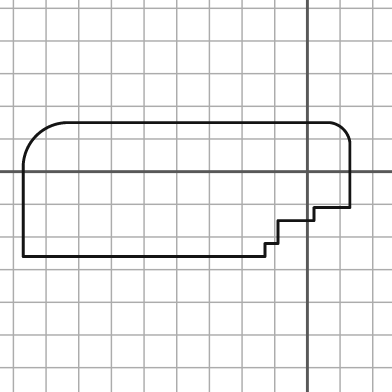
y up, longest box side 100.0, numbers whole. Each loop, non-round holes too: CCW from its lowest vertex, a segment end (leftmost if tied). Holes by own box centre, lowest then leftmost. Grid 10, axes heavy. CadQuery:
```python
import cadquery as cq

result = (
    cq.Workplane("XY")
    .moveTo(-87.0, -26.0)
    .lineTo(-13.0, -26.0)
    .lineTo(-13.0, -22.0)
    .lineTo(-9.0, -22.0)
    .lineTo(-9.0, -15.0)
    .lineTo(2.0, -15.0)
    .lineTo(2.0, -11.0)
    .lineTo(13.0, -11.0)
    .lineTo(13.0, 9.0)
    .threePointArc((11.0, 13.0), (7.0, 15.0))
    .lineTo(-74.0, 15.0)
    .threePointArc((-83.0, 11.0), (-87.0, 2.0))
    .close()
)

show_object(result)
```